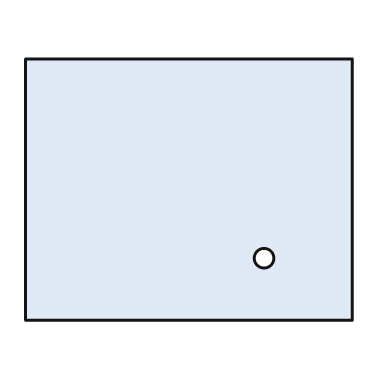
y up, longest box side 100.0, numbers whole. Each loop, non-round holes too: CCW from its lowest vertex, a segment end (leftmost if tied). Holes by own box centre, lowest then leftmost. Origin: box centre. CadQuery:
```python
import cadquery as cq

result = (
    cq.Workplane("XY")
    .moveTo(-50.0, -40.0)
    .lineTo(50.0, -40.0)
    .lineTo(50.0, 40.0)
    .lineTo(-50.0, 40.0)
    .close()
    .moveTo(23.0, -21.0)
    .circle(3.0)
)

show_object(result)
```